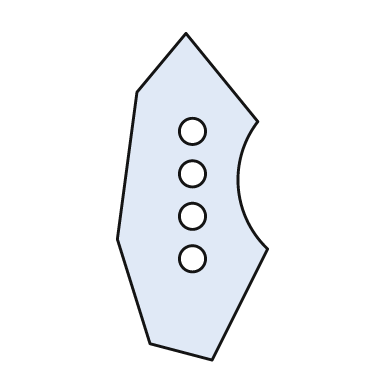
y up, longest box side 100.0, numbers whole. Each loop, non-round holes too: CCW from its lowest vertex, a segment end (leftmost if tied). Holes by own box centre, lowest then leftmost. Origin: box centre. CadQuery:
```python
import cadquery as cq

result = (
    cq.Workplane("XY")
    .moveTo(6.0, -50.0)
    .lineTo(23.0, -16.0)
    .threePointArc((14.0, 3.0), (20.0, 23.0))
    .lineTo(-2.0, 50.0)
    .lineTo(-17.0, 32.0)
    .lineTo(-23.0, -13.0)
    .lineTo(-13.0, -45.0)
    .close()
    .moveTo(0.0, -19.0)
    .circle(4.0)
    .moveTo(0.0, -6.0)
    .circle(4.0)
    .moveTo(0.0, 7.0)
    .circle(4.0)
    .moveTo(0.0, 20.0)
    .circle(4.0)
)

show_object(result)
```